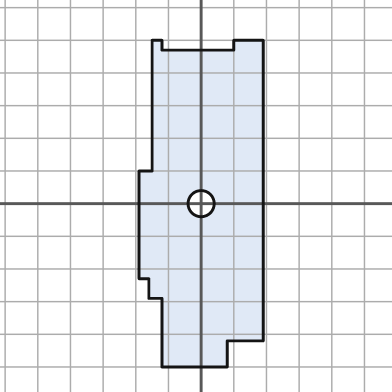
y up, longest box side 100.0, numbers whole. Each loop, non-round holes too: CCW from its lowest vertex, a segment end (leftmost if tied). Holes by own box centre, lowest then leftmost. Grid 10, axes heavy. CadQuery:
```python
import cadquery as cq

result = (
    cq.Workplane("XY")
    .moveTo(-12.0, -50.0)
    .lineTo(8.0, -50.0)
    .lineTo(8.0, -42.0)
    .lineTo(19.0, -42.0)
    .lineTo(19.0, 50.0)
    .lineTo(10.0, 50.0)
    .lineTo(10.0, 47.0)
    .lineTo(-12.0, 47.0)
    .lineTo(-12.0, 50.0)
    .lineTo(-15.0, 50.0)
    .lineTo(-15.0, 10.0)
    .lineTo(-19.0, 10.0)
    .lineTo(-19.0, -23.0)
    .lineTo(-16.0, -23.0)
    .lineTo(-16.0, -29.0)
    .lineTo(-12.0, -29.0)
    .close()
    .moveTo(0.0, 0.0)
    .circle(4.0)
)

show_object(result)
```